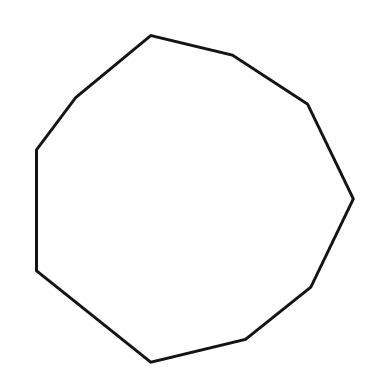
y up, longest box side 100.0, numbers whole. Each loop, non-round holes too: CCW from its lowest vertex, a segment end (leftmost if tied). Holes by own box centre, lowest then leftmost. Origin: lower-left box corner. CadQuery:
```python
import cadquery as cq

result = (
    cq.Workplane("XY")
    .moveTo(35.0, 0.0)
    .lineTo(64.0, 7.0)
    .lineTo(84.0, 23.0)
    .lineTo(97.0, 50.0)
    .lineTo(83.0, 79.0)
    .lineTo(60.0, 94.0)
    .lineTo(35.0, 100.0)
    .lineTo(12.0, 81.0)
    .lineTo(0.0, 65.0)
    .lineTo(0.0, 28.0)
    .close()
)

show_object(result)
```